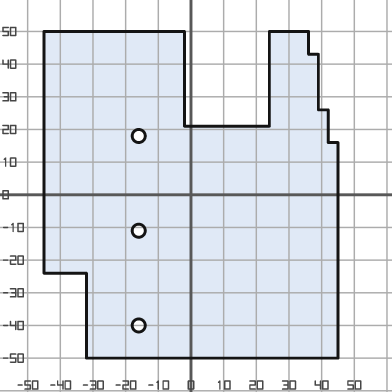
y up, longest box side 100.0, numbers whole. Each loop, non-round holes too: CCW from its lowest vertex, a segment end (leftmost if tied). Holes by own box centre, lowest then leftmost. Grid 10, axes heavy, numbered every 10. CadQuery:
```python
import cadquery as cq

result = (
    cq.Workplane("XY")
    .moveTo(-32.0, -50.0)
    .lineTo(45.0, -50.0)
    .lineTo(45.0, 16.0)
    .lineTo(42.0, 16.0)
    .lineTo(42.0, 26.0)
    .lineTo(39.0, 26.0)
    .lineTo(39.0, 43.0)
    .lineTo(36.0, 43.0)
    .lineTo(36.0, 50.0)
    .lineTo(24.0, 50.0)
    .lineTo(24.0, 21.0)
    .lineTo(-2.0, 21.0)
    .lineTo(-2.0, 50.0)
    .lineTo(-45.0, 50.0)
    .lineTo(-45.0, -24.0)
    .lineTo(-32.0, -24.0)
    .close()
    .moveTo(-16.0, -40.0)
    .circle(2.0)
    .moveTo(-16.0, -11.0)
    .circle(2.0)
    .moveTo(-16.0, 18.0)
    .circle(2.0)
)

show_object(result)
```